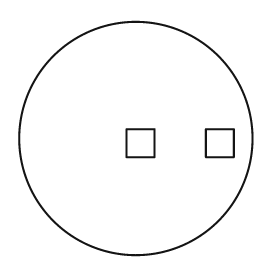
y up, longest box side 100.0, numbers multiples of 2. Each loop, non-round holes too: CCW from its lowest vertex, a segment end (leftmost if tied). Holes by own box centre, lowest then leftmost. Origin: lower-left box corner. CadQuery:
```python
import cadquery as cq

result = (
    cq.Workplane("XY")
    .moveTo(50.0, 50.0)
    .circle(50.0)
    .moveTo(46.0, 42.0)
    .lineTo(58.0, 42.0)
    .lineTo(58.0, 54.0)
    .lineTo(46.0, 54.0)
    .close()
    .moveTo(80.0, 42.0)
    .lineTo(92.0, 42.0)
    .lineTo(92.0, 54.0)
    .lineTo(80.0, 54.0)
    .close()
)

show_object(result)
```